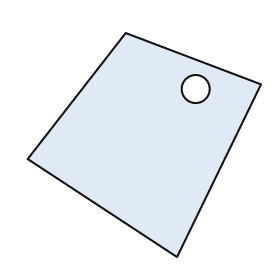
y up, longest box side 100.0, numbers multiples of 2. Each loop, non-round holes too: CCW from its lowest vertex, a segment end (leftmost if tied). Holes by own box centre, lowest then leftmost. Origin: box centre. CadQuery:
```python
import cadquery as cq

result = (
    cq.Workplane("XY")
    .moveTo(14.0, -48.0)
    .lineTo(50.0, 26.0)
    .lineTo(-8.0, 48.0)
    .lineTo(-50.0, -6.0)
    .close()
    .moveTo(22.0, 24.0)
    .circle(6.0)
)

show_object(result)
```